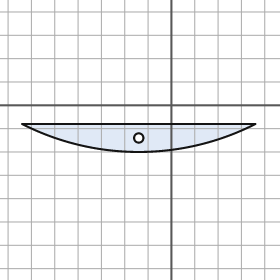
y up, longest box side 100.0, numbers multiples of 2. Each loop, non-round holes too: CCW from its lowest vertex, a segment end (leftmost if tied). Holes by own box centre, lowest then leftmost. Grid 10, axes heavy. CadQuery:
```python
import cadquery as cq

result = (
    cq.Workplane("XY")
    .moveTo(-64.0, -8.0)
    .threePointArc((-14.0, -20.0), (36.0, -8.0))
    .close()
    .moveTo(-14.0, -14.0)
    .circle(2.0)
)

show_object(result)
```